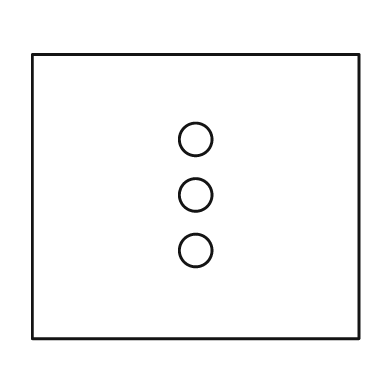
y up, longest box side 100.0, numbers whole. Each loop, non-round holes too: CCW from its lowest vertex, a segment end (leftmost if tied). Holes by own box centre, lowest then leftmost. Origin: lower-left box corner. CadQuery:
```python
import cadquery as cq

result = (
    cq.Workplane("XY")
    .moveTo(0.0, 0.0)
    .lineTo(100.0, 0.0)
    .lineTo(100.0, 87.0)
    .lineTo(0.0, 87.0)
    .close()
    .moveTo(50.0, 27.0)
    .circle(5.0)
    .moveTo(50.0, 44.0)
    .circle(5.0)
    .moveTo(50.0, 61.0)
    .circle(5.0)
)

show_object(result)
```